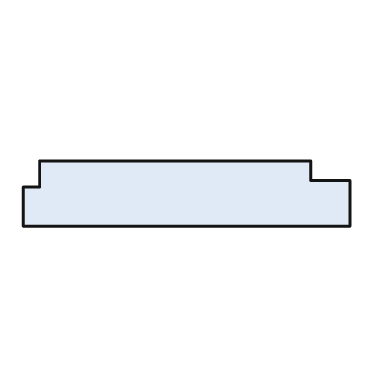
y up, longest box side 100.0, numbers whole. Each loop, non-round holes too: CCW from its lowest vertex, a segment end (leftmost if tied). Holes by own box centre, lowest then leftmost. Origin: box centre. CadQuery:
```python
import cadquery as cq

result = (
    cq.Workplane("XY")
    .moveTo(-50.0, -10.0)
    .lineTo(50.0, -10.0)
    .lineTo(50.0, 4.0)
    .lineTo(38.0, 4.0)
    .lineTo(38.0, 10.0)
    .lineTo(-45.0, 10.0)
    .lineTo(-45.0, 2.0)
    .lineTo(-50.0, 2.0)
    .close()
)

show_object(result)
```